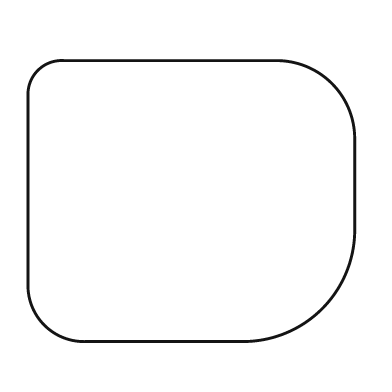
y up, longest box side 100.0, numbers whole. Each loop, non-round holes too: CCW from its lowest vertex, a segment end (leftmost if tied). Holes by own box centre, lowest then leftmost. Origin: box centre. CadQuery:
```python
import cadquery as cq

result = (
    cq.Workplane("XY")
    .moveTo(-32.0, -43.0)
    .lineTo(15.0, -43.0)
    .threePointArc((40.0, -33.0), (50.0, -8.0))
    .lineTo(50.0, 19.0)
    .threePointArc((43.0, 36.0), (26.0, 43.0))
    .lineTo(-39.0, 43.0)
    .threePointArc((-47.0, 40.0), (-50.0, 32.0))
    .lineTo(-50.0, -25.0)
    .threePointArc((-45.0, -38.0), (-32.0, -43.0))
    .close()
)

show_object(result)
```